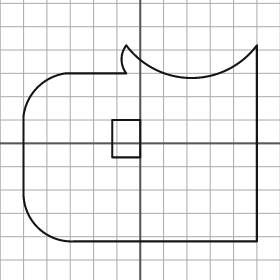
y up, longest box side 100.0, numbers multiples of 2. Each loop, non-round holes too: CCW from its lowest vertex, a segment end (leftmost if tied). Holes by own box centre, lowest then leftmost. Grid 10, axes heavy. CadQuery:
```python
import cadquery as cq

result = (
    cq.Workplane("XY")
    .moveTo(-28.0, -42.0)
    .lineTo(50.0, -42.0)
    .lineTo(50.0, 42.0)
    .threePointArc((22.0, 28.0), (-6.0, 42.0))
    .threePointArc((-8.0, 36.0), (-6.0, 30.0))
    .lineTo(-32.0, 30.0)
    .threePointArc((-44.0, 24.0), (-50.0, 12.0))
    .lineTo(-50.0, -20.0)
    .threePointArc((-44.0, -36.0), (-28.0, -42.0))
    .close()
    .moveTo(-12.0, -6.0)
    .lineTo(0.0, -6.0)
    .lineTo(0.0, 10.0)
    .lineTo(-12.0, 10.0)
    .close()
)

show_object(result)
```